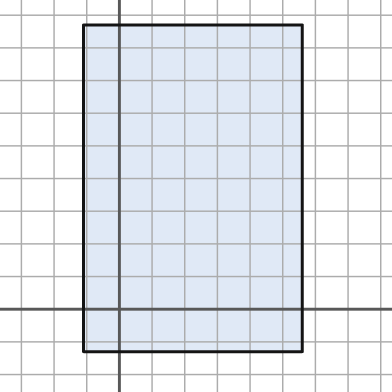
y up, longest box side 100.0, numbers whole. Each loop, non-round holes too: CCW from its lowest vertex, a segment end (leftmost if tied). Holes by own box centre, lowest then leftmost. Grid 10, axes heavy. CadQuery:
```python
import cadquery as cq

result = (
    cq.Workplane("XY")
    .moveTo(-11.0, -13.0)
    .lineTo(56.0, -13.0)
    .lineTo(56.0, 87.0)
    .lineTo(-11.0, 87.0)
    .close()
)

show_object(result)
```